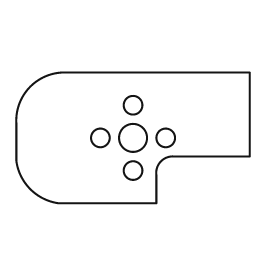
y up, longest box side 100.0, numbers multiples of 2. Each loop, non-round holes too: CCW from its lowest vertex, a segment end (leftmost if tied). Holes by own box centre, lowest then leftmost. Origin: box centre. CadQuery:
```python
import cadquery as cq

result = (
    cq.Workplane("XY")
    .moveTo(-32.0, -28.0)
    .lineTo(10.0, -28.0)
    .lineTo(10.0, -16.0)
    .threePointArc((12.0, -10.0), (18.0, -8.0))
    .lineTo(50.0, -8.0)
    .lineTo(50.0, 28.0)
    .lineTo(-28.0, 28.0)
    .threePointArc((-44.0, 22.0), (-50.0, 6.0))
    .lineTo(-50.0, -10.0)
    .threePointArc((-44.0, -22.0), (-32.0, -28.0))
    .close()
    .moveTo(0.0, -14.0)
    .circle(4.0)
    .moveTo(-14.0, 0.0)
    .circle(4.0)
    .moveTo(0.0, 0.0)
    .circle(6.0)
    .moveTo(14.0, 0.0)
    .circle(4.0)
    .moveTo(0.0, 14.0)
    .circle(4.0)
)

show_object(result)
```